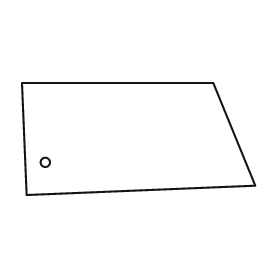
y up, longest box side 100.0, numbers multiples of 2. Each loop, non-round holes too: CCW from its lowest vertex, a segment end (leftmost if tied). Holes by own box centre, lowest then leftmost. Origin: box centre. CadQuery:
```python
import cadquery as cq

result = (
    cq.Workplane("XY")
    .moveTo(-48.0, -24.0)
    .lineTo(50.0, -20.0)
    .lineTo(32.0, 24.0)
    .lineTo(-50.0, 24.0)
    .close()
    .moveTo(-40.0, -10.0)
    .circle(2.0)
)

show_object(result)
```